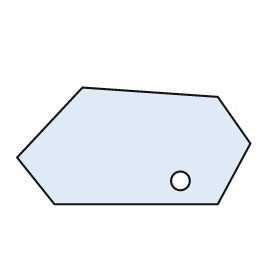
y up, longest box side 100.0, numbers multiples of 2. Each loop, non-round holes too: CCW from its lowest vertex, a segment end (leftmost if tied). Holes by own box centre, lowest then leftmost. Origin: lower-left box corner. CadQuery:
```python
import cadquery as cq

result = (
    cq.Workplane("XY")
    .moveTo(16.0, 0.0)
    .lineTo(86.0, 0.0)
    .lineTo(100.0, 26.0)
    .lineTo(86.0, 46.0)
    .lineTo(28.0, 50.0)
    .lineTo(0.0, 20.0)
    .close()
    .moveTo(70.0, 10.0)
    .circle(4.0)
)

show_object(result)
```